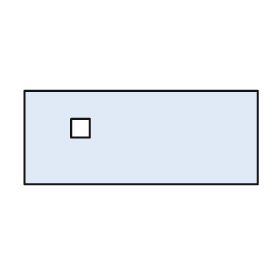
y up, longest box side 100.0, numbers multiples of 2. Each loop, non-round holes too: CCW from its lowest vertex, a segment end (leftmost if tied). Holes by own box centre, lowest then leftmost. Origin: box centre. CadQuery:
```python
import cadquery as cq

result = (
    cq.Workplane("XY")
    .moveTo(-50.0, -20.0)
    .lineTo(50.0, -20.0)
    .lineTo(50.0, 20.0)
    .lineTo(-50.0, 20.0)
    .close()
    .moveTo(-30.0, 0.0)
    .lineTo(-22.0, 0.0)
    .lineTo(-22.0, 8.0)
    .lineTo(-30.0, 8.0)
    .close()
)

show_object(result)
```